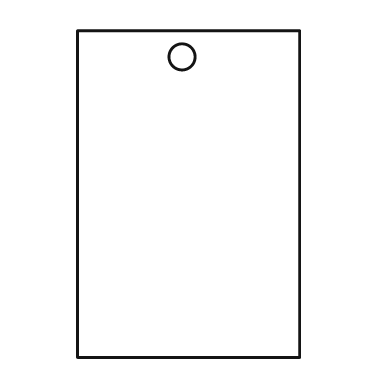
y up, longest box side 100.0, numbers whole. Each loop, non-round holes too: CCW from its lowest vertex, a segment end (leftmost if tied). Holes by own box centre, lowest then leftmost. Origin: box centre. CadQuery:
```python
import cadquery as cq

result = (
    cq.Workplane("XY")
    .moveTo(-34.0, -50.0)
    .lineTo(34.0, -50.0)
    .lineTo(34.0, 50.0)
    .lineTo(-34.0, 50.0)
    .close()
    .moveTo(-2.0, 42.0)
    .circle(4.0)
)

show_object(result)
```